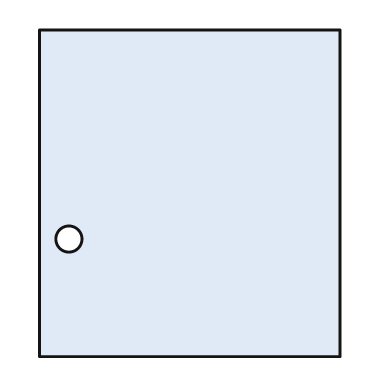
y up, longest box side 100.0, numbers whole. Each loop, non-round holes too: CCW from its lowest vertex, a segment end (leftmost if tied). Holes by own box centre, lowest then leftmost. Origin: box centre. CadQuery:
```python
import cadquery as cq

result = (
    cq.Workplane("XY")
    .moveTo(-46.0, -50.0)
    .lineTo(46.0, -50.0)
    .lineTo(46.0, 50.0)
    .lineTo(-46.0, 50.0)
    .close()
    .moveTo(-37.0, -14.0)
    .circle(4.0)
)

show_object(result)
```